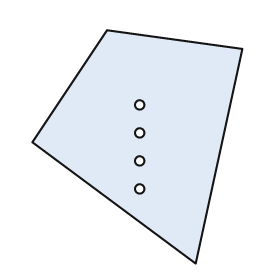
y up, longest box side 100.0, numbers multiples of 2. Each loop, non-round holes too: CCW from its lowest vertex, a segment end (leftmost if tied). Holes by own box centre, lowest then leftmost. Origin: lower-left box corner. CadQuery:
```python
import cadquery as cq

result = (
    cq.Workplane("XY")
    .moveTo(70.0, 0.0)
    .lineTo(90.0, 92.0)
    .lineTo(32.0, 100.0)
    .lineTo(0.0, 52.0)
    .close()
    .moveTo(46.0, 32.0)
    .circle(2.0)
    .moveTo(46.0, 44.0)
    .circle(2.0)
    .moveTo(46.0, 56.0)
    .circle(2.0)
    .moveTo(46.0, 68.0)
    .circle(2.0)
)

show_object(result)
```